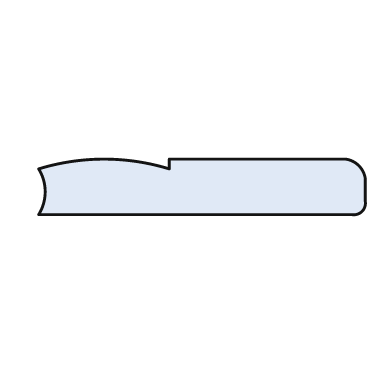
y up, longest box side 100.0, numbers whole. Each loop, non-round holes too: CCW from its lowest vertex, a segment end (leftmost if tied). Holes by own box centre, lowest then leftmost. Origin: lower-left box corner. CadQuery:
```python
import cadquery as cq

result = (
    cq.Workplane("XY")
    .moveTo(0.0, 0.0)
    .lineTo(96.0, 0.0)
    .threePointArc((99.0, 1.0), (100.0, 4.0))
    .lineTo(100.0, 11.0)
    .threePointArc((98.0, 15.0), (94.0, 17.0))
    .lineTo(40.0, 17.0)
    .lineTo(40.0, 14.0)
    .threePointArc((20.0, 17.0), (0.0, 14.0))
    .threePointArc((2.0, 7.0), (0.0, 0.0))
    .close()
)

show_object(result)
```